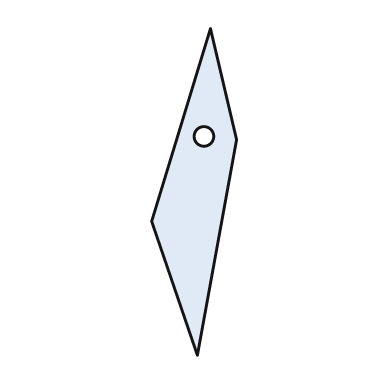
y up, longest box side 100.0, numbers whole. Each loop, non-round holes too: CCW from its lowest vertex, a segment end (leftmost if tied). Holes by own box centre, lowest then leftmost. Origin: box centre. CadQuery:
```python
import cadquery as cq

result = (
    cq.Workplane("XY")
    .moveTo(1.0, -50.0)
    .lineTo(13.0, 16.0)
    .lineTo(5.0, 50.0)
    .lineTo(-13.0, -9.0)
    .close()
    .moveTo(3.0, 17.0)
    .circle(3.0)
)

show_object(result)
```